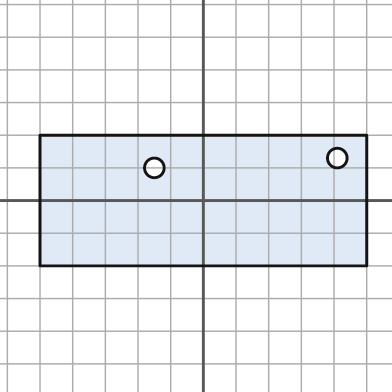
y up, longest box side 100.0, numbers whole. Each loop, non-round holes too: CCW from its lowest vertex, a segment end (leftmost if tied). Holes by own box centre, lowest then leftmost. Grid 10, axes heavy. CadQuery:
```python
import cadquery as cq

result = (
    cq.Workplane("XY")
    .moveTo(-50.0, -20.0)
    .lineTo(50.0, -20.0)
    .lineTo(50.0, 20.0)
    .lineTo(-50.0, 20.0)
    .close()
    .moveTo(-15.0, 10.0)
    .circle(3.0)
    .moveTo(41.0, 13.0)
    .circle(3.0)
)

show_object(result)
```